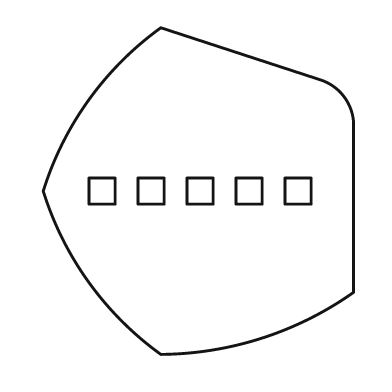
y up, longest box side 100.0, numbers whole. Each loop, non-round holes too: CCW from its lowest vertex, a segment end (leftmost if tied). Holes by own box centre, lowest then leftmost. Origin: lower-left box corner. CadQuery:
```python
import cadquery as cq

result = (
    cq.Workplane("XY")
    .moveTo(36.0, 0.0)
    .threePointArc((67.0, 5.0), (95.0, 19.0))
    .lineTo(95.0, 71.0)
    .threePointArc((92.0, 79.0), (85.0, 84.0))
    .lineTo(36.0, 100.0)
    .threePointArc((14.0, 78.0), (0.0, 50.0))
    .threePointArc((14.0, 22.0), (36.0, 0.0))
    .close()
    .moveTo(14.0, 46.0)
    .lineTo(22.0, 46.0)
    .lineTo(22.0, 54.0)
    .lineTo(14.0, 54.0)
    .close()
    .moveTo(29.0, 46.0)
    .lineTo(37.0, 46.0)
    .lineTo(37.0, 54.0)
    .lineTo(29.0, 54.0)
    .close()
    .moveTo(44.0, 46.0)
    .lineTo(52.0, 46.0)
    .lineTo(52.0, 54.0)
    .lineTo(44.0, 54.0)
    .close()
    .moveTo(59.0, 46.0)
    .lineTo(67.0, 46.0)
    .lineTo(67.0, 54.0)
    .lineTo(59.0, 54.0)
    .close()
    .moveTo(74.0, 46.0)
    .lineTo(82.0, 46.0)
    .lineTo(82.0, 54.0)
    .lineTo(74.0, 54.0)
    .close()
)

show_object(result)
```